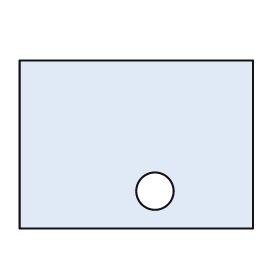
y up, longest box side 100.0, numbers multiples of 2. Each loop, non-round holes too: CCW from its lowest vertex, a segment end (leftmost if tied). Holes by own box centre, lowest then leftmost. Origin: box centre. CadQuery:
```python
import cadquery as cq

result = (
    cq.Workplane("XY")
    .moveTo(-50.0, -36.0)
    .lineTo(50.0, -36.0)
    .lineTo(50.0, 36.0)
    .lineTo(-50.0, 36.0)
    .close()
    .moveTo(8.0, -20.0)
    .circle(8.0)
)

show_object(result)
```